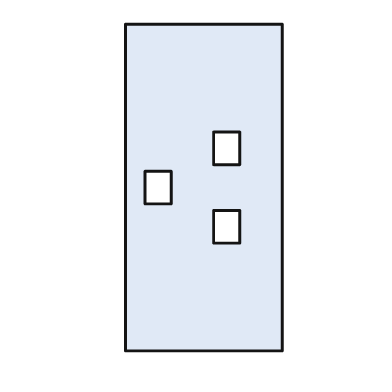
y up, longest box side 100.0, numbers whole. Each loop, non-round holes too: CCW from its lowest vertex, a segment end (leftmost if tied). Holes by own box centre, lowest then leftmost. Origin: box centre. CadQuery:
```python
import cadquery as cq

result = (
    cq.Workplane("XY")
    .moveTo(-24.0, -50.0)
    .lineTo(24.0, -50.0)
    .lineTo(24.0, 50.0)
    .lineTo(-24.0, 50.0)
    .close()
    .moveTo(3.0, -17.0)
    .lineTo(11.0, -17.0)
    .lineTo(11.0, -7.0)
    .lineTo(3.0, -7.0)
    .close()
    .moveTo(-18.0, -5.0)
    .lineTo(-10.0, -5.0)
    .lineTo(-10.0, 5.0)
    .lineTo(-18.0, 5.0)
    .close()
    .moveTo(3.0, 7.0)
    .lineTo(11.0, 7.0)
    .lineTo(11.0, 17.0)
    .lineTo(3.0, 17.0)
    .close()
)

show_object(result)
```